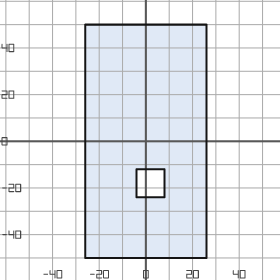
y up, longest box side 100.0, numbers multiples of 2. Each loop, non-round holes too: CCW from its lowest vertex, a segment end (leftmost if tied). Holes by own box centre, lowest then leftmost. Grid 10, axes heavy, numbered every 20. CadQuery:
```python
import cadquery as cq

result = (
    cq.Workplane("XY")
    .moveTo(-26.0, -50.0)
    .lineTo(26.0, -50.0)
    .lineTo(26.0, 50.0)
    .lineTo(-26.0, 50.0)
    .close()
    .moveTo(-4.0, -24.0)
    .lineTo(8.0, -24.0)
    .lineTo(8.0, -12.0)
    .lineTo(-4.0, -12.0)
    .close()
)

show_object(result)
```